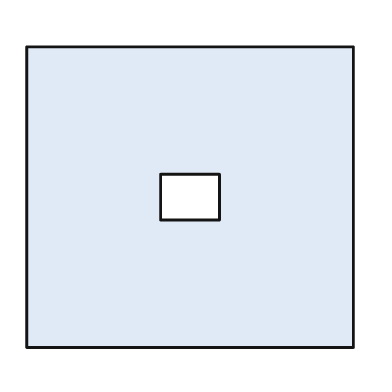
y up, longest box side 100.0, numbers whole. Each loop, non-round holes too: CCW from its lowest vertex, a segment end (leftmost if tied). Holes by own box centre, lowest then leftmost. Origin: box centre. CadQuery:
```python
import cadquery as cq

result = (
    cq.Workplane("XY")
    .moveTo(-50.0, -46.0)
    .lineTo(50.0, -46.0)
    .lineTo(50.0, 46.0)
    .lineTo(-50.0, 46.0)
    .close()
    .moveTo(-9.0, -7.0)
    .lineTo(9.0, -7.0)
    .lineTo(9.0, 7.0)
    .lineTo(-9.0, 7.0)
    .close()
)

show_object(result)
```